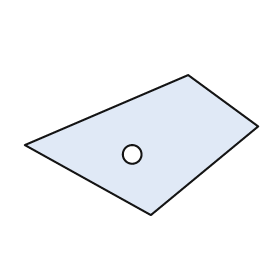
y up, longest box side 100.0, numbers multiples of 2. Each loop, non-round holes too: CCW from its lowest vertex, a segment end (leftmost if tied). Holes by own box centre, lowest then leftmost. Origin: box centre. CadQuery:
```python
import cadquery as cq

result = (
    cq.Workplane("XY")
    .moveTo(4.0, -30.0)
    .lineTo(50.0, 8.0)
    .lineTo(20.0, 30.0)
    .lineTo(-50.0, 0.0)
    .close()
    .moveTo(-4.0, -4.0)
    .circle(4.0)
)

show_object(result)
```